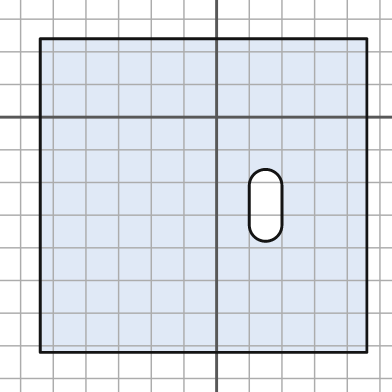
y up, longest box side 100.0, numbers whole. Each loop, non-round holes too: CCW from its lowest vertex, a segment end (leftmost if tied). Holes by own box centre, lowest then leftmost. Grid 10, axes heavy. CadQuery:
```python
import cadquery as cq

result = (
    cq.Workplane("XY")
    .moveTo(-54.0, -72.0)
    .lineTo(46.0, -72.0)
    .lineTo(46.0, 24.0)
    .lineTo(-54.0, 24.0)
    .close()
    .moveTo(10.0, -33.0)
    .threePointArc((15.0, -38.0), (20.0, -33.0))
    .lineTo(20.0, -21.0)
    .threePointArc((15.0, -16.0), (10.0, -21.0))
    .close()
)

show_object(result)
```